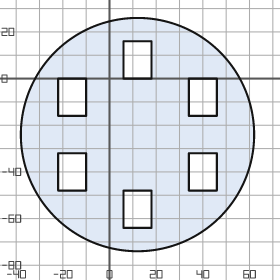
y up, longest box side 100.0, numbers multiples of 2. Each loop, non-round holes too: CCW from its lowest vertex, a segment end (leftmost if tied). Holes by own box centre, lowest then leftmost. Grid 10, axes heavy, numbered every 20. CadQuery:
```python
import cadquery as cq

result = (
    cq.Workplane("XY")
    .moveTo(12.0, -24.0)
    .circle(50.0)
    .moveTo(6.0, -64.0)
    .lineTo(18.0, -64.0)
    .lineTo(18.0, -48.0)
    .lineTo(6.0, -48.0)
    .close()
    .moveTo(-22.0, -48.0)
    .lineTo(-10.0, -48.0)
    .lineTo(-10.0, -32.0)
    .lineTo(-22.0, -32.0)
    .close()
    .moveTo(34.0, -48.0)
    .lineTo(46.0, -48.0)
    .lineTo(46.0, -32.0)
    .lineTo(34.0, -32.0)
    .close()
    .moveTo(-22.0, -16.0)
    .lineTo(-10.0, -16.0)
    .lineTo(-10.0, 0.0)
    .lineTo(-22.0, 0.0)
    .close()
    .moveTo(34.0, -16.0)
    .lineTo(46.0, -16.0)
    .lineTo(46.0, 0.0)
    .lineTo(34.0, 0.0)
    .close()
    .moveTo(6.0, 0.0)
    .lineTo(18.0, 0.0)
    .lineTo(18.0, 16.0)
    .lineTo(6.0, 16.0)
    .close()
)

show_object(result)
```